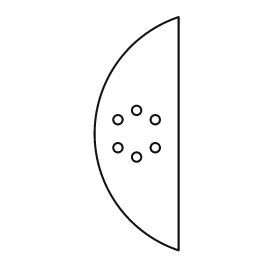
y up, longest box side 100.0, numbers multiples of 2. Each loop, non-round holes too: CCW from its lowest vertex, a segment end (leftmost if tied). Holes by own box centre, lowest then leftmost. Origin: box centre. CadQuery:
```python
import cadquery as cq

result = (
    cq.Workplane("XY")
    .moveTo(18.0, -50.0)
    .lineTo(18.0, 50.0)
    .threePointArc((-18.0, 0.0), (18.0, -50.0))
    .close()
    .moveTo(0.0, -10.0)
    .circle(2.0)
    .moveTo(-8.0, -6.0)
    .circle(2.0)
    .moveTo(8.0, -6.0)
    .circle(2.0)
    .moveTo(-8.0, 6.0)
    .circle(2.0)
    .moveTo(8.0, 6.0)
    .circle(2.0)
    .moveTo(0.0, 10.0)
    .circle(2.0)
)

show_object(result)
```